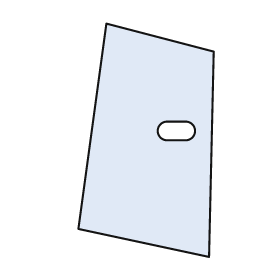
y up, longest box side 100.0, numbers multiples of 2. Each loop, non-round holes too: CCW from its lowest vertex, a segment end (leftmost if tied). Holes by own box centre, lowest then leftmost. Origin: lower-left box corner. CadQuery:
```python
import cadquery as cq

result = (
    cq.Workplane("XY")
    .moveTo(56.0, 0.0)
    .lineTo(58.0, 88.0)
    .lineTo(12.0, 100.0)
    .lineTo(0.0, 12.0)
    .close()
    .moveTo(38.0, 50.0)
    .lineTo(46.0, 50.0)
    .threePointArc((50.0, 54.0), (46.0, 58.0))
    .lineTo(38.0, 58.0)
    .threePointArc((34.0, 54.0), (38.0, 50.0))
    .close()
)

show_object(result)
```